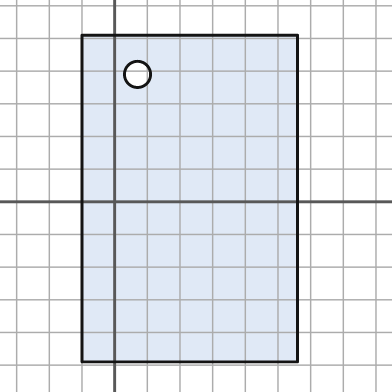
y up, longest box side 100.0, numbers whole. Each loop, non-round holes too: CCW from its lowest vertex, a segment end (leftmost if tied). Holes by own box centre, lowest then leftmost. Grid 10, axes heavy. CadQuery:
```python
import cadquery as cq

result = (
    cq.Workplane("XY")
    .moveTo(-10.0, -49.0)
    .lineTo(56.0, -49.0)
    .lineTo(56.0, 51.0)
    .lineTo(-10.0, 51.0)
    .close()
    .moveTo(7.0, 39.0)
    .circle(4.0)
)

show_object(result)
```